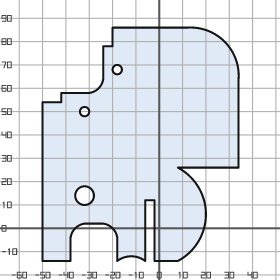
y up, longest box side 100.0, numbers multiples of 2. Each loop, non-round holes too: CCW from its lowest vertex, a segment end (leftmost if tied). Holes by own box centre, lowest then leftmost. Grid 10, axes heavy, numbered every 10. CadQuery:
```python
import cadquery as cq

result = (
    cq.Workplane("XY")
    .moveTo(-50.0, -14.0)
    .lineTo(-38.0, -14.0)
    .lineTo(-38.0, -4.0)
    .threePointArc((-36.0, 0.0), (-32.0, 2.0))
    .lineTo(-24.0, 2.0)
    .threePointArc((-20.0, 0.0), (-18.0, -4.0))
    .lineTo(-18.0, -14.0)
    .threePointArc((-12.0, -12.0), (-6.0, -14.0))
    .lineTo(-6.0, 12.0)
    .lineTo(-2.0, 12.0)
    .lineTo(-2.0, -14.0)
    .lineTo(8.0, -14.0)
    .threePointArc((20.0, 6.0), (8.0, 26.0))
    .lineTo(34.0, 26.0)
    .lineTo(34.0, 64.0)
    .threePointArc((28.0, 80.0), (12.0, 86.0))
    .lineTo(-20.0, 86.0)
    .lineTo(-20.0, 78.0)
    .lineTo(-24.0, 78.0)
    .lineTo(-24.0, 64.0)
    .threePointArc((-26.0, 60.0), (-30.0, 58.0))
    .lineTo(-42.0, 58.0)
    .lineTo(-42.0, 54.0)
    .lineTo(-50.0, 54.0)
    .close()
    .moveTo(-32.0, 14.0)
    .circle(4.0)
    .moveTo(-32.0, 50.0)
    .circle(2.0)
    .moveTo(-18.0, 68.0)
    .circle(2.0)
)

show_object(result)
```